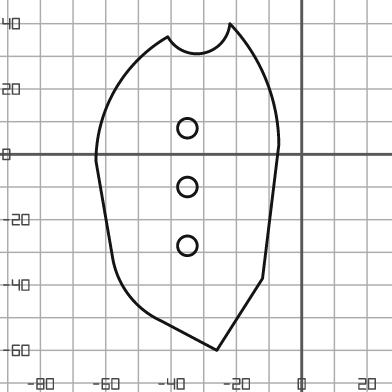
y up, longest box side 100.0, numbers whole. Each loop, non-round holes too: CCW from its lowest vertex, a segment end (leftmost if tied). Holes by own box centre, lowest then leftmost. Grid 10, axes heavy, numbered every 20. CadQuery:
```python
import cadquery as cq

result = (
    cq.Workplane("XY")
    .moveTo(-26.0, -60.0)
    .lineTo(-12.0, -38.0)
    .lineTo(-7.0, 3.0)
    .threePointArc((-11.0, 23.0), (-22.0, 40.0))
    .threePointArc((-30.0, 31.0), (-41.0, 36.0))
    .threePointArc((-57.0, 20.0), (-63.0, -2.0))
    .lineTo(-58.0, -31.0)
    .threePointArc((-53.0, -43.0), (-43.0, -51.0))
    .close()
    .moveTo(-35.0, -28.0)
    .circle(3.0)
    .moveTo(-35.0, -10.0)
    .circle(3.0)
    .moveTo(-35.0, 8.0)
    .circle(3.0)
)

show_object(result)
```